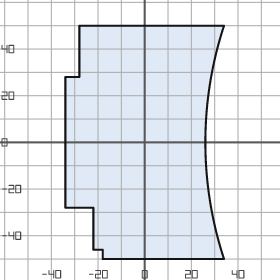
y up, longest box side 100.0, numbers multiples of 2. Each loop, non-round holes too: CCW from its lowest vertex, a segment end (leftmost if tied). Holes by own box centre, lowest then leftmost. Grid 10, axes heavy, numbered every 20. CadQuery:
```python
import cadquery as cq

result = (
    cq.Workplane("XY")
    .moveTo(-18.0, -50.0)
    .lineTo(34.0, -50.0)
    .threePointArc((26.0, 0.0), (34.0, 50.0))
    .lineTo(-28.0, 50.0)
    .lineTo(-28.0, 28.0)
    .lineTo(-34.0, 28.0)
    .lineTo(-34.0, -28.0)
    .lineTo(-22.0, -28.0)
    .lineTo(-22.0, -46.0)
    .lineTo(-18.0, -46.0)
    .close()
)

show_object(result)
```